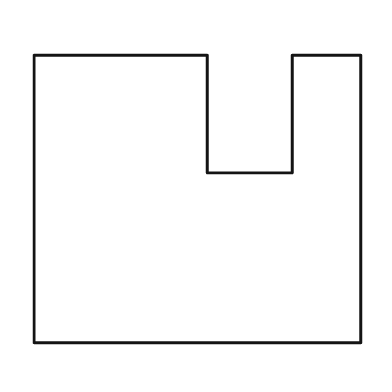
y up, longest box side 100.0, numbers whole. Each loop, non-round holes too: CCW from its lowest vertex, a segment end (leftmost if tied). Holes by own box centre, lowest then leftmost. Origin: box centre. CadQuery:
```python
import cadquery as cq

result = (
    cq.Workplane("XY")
    .moveTo(-50.0, -44.0)
    .lineTo(50.0, -44.0)
    .lineTo(50.0, 44.0)
    .lineTo(29.0, 44.0)
    .lineTo(29.0, 8.0)
    .lineTo(3.0, 8.0)
    .lineTo(3.0, 44.0)
    .lineTo(-50.0, 44.0)
    .close()
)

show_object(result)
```